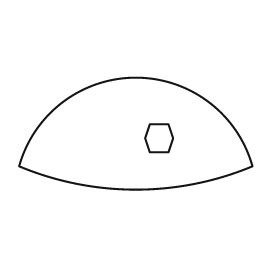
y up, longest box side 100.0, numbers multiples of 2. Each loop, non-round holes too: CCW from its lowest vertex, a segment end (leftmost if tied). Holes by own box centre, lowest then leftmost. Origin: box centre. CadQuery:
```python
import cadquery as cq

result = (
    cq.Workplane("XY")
    .moveTo(-50.0, -14.0)
    .threePointArc((0.0, -24.0), (50.0, -14.0))
    .threePointArc((0.0, 24.0), (-50.0, -14.0))
    .close()
    .moveTo(6.0, -8.0)
    .lineTo(14.0, -8.0)
    .lineTo(16.0, -2.0)
    .lineTo(14.0, 4.0)
    .lineTo(6.0, 4.0)
    .lineTo(4.0, -2.0)
    .close()
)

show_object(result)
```